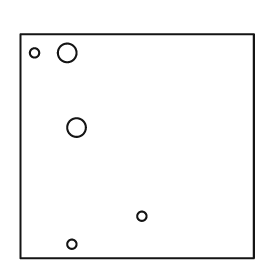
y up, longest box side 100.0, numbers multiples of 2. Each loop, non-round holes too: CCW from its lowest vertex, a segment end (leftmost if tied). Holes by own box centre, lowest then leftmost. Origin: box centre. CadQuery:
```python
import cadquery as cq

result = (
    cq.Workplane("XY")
    .moveTo(-50.0, -48.0)
    .lineTo(50.0, -48.0)
    .lineTo(50.0, 48.0)
    .lineTo(-50.0, 48.0)
    .close()
    .moveTo(-28.0, -42.0)
    .circle(2.0)
    .moveTo(2.0, -30.0)
    .circle(2.0)
    .moveTo(-26.0, 8.0)
    .circle(4.0)
    .moveTo(-44.0, 40.0)
    .circle(2.0)
    .moveTo(-30.0, 40.0)
    .circle(4.0)
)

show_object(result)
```